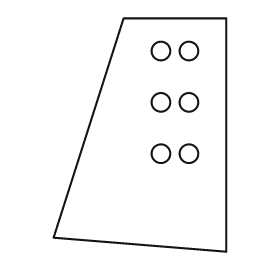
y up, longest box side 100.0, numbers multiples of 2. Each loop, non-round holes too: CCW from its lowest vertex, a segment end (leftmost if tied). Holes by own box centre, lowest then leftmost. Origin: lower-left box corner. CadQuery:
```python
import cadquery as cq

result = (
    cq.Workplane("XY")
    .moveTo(74.0, 0.0)
    .lineTo(74.0, 100.0)
    .lineTo(30.0, 100.0)
    .lineTo(0.0, 6.0)
    .close()
    .moveTo(46.0, 42.0)
    .circle(4.0)
    .moveTo(58.0, 42.0)
    .circle(4.0)
    .moveTo(46.0, 64.0)
    .circle(4.0)
    .moveTo(58.0, 64.0)
    .circle(4.0)
    .moveTo(46.0, 86.0)
    .circle(4.0)
    .moveTo(58.0, 86.0)
    .circle(4.0)
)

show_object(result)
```